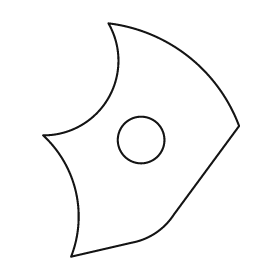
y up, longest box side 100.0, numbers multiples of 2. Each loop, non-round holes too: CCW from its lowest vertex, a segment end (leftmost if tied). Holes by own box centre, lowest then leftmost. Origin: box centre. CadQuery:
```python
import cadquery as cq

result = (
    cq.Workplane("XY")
    .moveTo(-30.0, -50.0)
    .lineTo(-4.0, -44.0)
    .threePointArc((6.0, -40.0), (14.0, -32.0))
    .lineTo(42.0, 6.0)
    .threePointArc((20.0, 36.0), (-14.0, 50.0))
    .threePointArc((-14.0, 18.0), (-42.0, 2.0))
    .threePointArc((-28.0, -22.0), (-30.0, -50.0))
    .close()
    .moveTo(0.0, 0.0)
    .circle(10.0)
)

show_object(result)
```